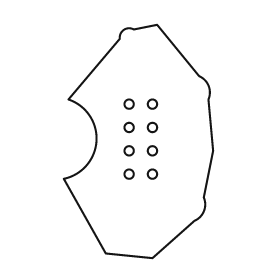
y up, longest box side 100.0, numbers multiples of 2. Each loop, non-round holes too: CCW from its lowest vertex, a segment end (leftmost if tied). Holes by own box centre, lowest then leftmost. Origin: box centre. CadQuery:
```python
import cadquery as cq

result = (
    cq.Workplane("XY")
    .moveTo(6.0, -50.0)
    .lineTo(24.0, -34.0)
    .threePointArc((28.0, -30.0), (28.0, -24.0))
    .lineTo(32.0, -4.0)
    .lineTo(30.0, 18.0)
    .threePointArc((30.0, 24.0), (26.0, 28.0))
    .lineTo(8.0, 50.0)
    .lineTo(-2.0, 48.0)
    .threePointArc((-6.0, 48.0), (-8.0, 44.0))
    .lineTo(-30.0, 18.0)
    .threePointArc((-18.0, 0.0), (-32.0, -16.0))
    .lineTo(-14.0, -48.0)
    .close()
    .moveTo(-4.0, -14.0)
    .circle(2.0)
    .moveTo(6.0, -14.0)
    .circle(2.0)
    .moveTo(-4.0, -4.0)
    .circle(2.0)
    .moveTo(6.0, -4.0)
    .circle(2.0)
    .moveTo(-4.0, 6.0)
    .circle(2.0)
    .moveTo(6.0, 6.0)
    .circle(2.0)
    .moveTo(-4.0, 16.0)
    .circle(2.0)
    .moveTo(6.0, 16.0)
    .circle(2.0)
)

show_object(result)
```